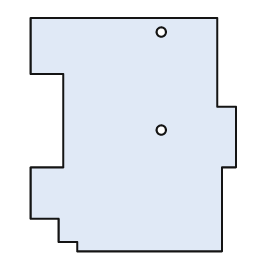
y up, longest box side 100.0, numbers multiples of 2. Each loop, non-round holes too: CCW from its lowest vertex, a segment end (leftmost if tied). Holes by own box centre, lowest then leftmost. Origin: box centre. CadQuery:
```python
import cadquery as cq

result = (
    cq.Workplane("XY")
    .moveTo(-24.0, -50.0)
    .lineTo(38.0, -50.0)
    .lineTo(38.0, -14.0)
    .lineTo(44.0, -14.0)
    .lineTo(44.0, 12.0)
    .lineTo(36.0, 12.0)
    .lineTo(36.0, 50.0)
    .lineTo(-44.0, 50.0)
    .lineTo(-44.0, 26.0)
    .lineTo(-30.0, 26.0)
    .lineTo(-30.0, -14.0)
    .lineTo(-44.0, -14.0)
    .lineTo(-44.0, -36.0)
    .lineTo(-32.0, -36.0)
    .lineTo(-32.0, -46.0)
    .lineTo(-24.0, -46.0)
    .close()
    .moveTo(12.0, 2.0)
    .circle(2.0)
    .moveTo(12.0, 44.0)
    .circle(2.0)
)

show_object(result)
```